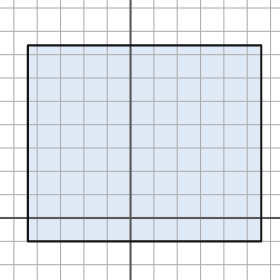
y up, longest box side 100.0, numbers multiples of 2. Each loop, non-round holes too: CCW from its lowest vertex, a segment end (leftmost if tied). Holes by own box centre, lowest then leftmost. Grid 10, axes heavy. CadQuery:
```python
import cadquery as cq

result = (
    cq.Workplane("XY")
    .moveTo(-44.0, -10.0)
    .lineTo(56.0, -10.0)
    .lineTo(56.0, 74.0)
    .lineTo(-44.0, 74.0)
    .close()
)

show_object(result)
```